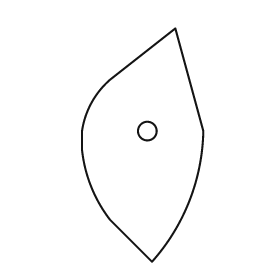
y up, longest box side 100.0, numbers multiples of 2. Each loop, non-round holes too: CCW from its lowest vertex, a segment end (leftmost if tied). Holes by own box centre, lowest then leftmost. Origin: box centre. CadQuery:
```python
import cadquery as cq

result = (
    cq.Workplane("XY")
    .moveTo(4.0, -50.0)
    .threePointArc((20.0, -24.0), (26.0, 6.0))
    .lineTo(14.0, 50.0)
    .lineTo(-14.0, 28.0)
    .threePointArc((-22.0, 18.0), (-26.0, 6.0))
    .lineTo(-26.0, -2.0)
    .threePointArc((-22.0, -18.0), (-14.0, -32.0))
    .close()
    .moveTo(2.0, 6.0)
    .circle(4.0)
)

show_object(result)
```